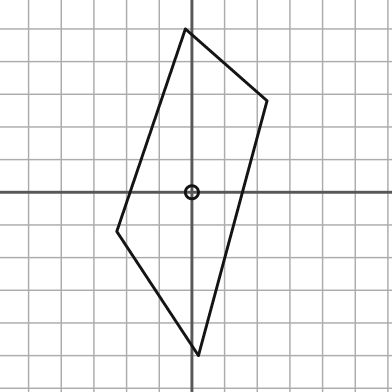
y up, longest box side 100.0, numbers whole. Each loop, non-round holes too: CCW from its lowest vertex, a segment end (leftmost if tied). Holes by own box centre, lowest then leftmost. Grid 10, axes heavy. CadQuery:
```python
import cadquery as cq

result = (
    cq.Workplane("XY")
    .moveTo(2.0, -50.0)
    .lineTo(23.0, 28.0)
    .lineTo(-2.0, 50.0)
    .lineTo(-23.0, -12.0)
    .close()
    .moveTo(0.0, 0.0)
    .circle(2.0)
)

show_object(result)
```